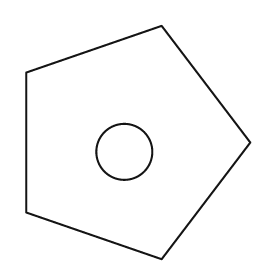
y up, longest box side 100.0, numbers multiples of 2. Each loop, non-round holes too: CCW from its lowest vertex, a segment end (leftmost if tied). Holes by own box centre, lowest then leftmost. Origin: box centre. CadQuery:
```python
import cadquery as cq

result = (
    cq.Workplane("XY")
    .moveTo(10.0, -50.0)
    .lineTo(48.0, 0.0)
    .lineTo(10.0, 50.0)
    .lineTo(-48.0, 30.0)
    .lineTo(-48.0, -30.0)
    .close()
    .moveTo(-6.0, -4.0)
    .circle(12.0)
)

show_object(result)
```